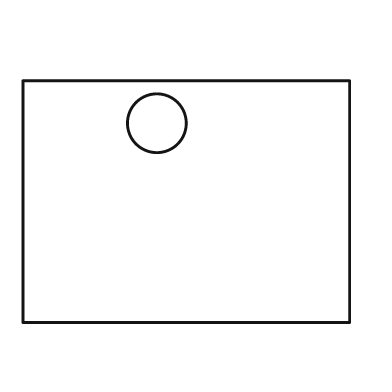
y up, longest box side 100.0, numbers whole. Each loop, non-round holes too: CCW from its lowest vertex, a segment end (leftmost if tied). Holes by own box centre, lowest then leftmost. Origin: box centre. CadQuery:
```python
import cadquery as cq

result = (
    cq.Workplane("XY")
    .moveTo(-50.0, -37.0)
    .lineTo(50.0, -37.0)
    .lineTo(50.0, 37.0)
    .lineTo(-50.0, 37.0)
    .close()
    .moveTo(-9.0, 24.0)
    .circle(9.0)
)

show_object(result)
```